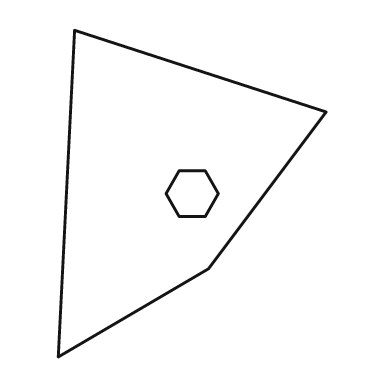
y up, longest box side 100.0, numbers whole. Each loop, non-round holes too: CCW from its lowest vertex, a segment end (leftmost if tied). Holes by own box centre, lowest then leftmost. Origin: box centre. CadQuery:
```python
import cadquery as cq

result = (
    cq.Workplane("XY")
    .moveTo(-41.0, -50.0)
    .lineTo(5.0, -23.0)
    .lineTo(41.0, 25.0)
    .lineTo(-36.0, 50.0)
    .close()
    .moveTo(-4.0, -7.0)
    .lineTo(4.0, -7.0)
    .lineTo(8.0, 0.0)
    .lineTo(4.0, 7.0)
    .lineTo(-4.0, 7.0)
    .lineTo(-8.0, 0.0)
    .close()
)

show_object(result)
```